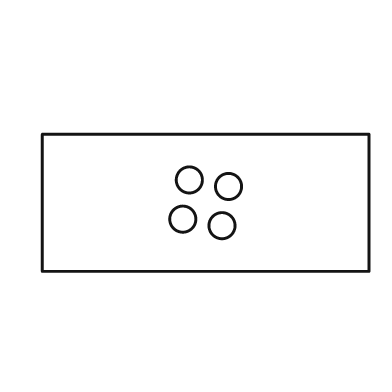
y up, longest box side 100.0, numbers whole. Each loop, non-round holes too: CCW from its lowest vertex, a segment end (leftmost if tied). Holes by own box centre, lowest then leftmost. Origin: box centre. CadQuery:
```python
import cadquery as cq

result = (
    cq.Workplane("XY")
    .moveTo(-50.0, -21.0)
    .lineTo(50.0, -21.0)
    .lineTo(50.0, 21.0)
    .lineTo(-50.0, 21.0)
    .close()
    .moveTo(5.0, -7.0)
    .circle(4.0)
    .moveTo(-7.0, -5.0)
    .circle(4.0)
    .moveTo(7.0, 5.0)
    .circle(4.0)
    .moveTo(-5.0, 7.0)
    .circle(4.0)
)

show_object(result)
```